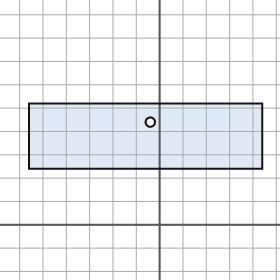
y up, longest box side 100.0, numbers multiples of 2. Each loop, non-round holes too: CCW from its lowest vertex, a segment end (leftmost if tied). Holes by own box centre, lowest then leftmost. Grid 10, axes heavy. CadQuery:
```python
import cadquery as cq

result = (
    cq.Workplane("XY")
    .moveTo(-56.0, 24.0)
    .lineTo(44.0, 24.0)
    .lineTo(44.0, 52.0)
    .lineTo(-56.0, 52.0)
    .close()
    .moveTo(-4.0, 44.0)
    .circle(2.0)
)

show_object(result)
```